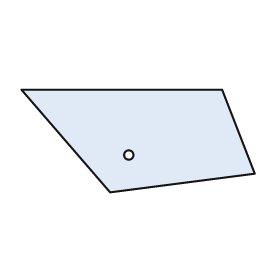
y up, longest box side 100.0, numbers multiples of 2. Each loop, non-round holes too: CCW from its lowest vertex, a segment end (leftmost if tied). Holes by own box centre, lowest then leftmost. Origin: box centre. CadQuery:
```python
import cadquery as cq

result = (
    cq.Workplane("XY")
    .moveTo(-12.0, -22.0)
    .lineTo(50.0, -14.0)
    .lineTo(36.0, 22.0)
    .lineTo(-50.0, 22.0)
    .close()
    .moveTo(-4.0, -6.0)
    .circle(2.0)
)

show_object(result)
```